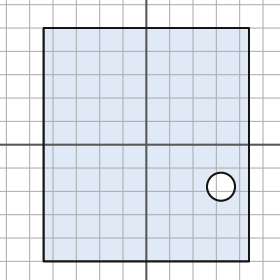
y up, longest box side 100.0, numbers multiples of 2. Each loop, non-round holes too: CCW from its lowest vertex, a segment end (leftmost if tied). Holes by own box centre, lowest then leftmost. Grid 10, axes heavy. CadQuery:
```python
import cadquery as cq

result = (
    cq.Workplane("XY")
    .moveTo(-44.0, -50.0)
    .lineTo(44.0, -50.0)
    .lineTo(44.0, 50.0)
    .lineTo(-44.0, 50.0)
    .close()
    .moveTo(32.0, -18.0)
    .circle(6.0)
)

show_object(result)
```